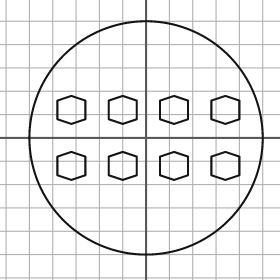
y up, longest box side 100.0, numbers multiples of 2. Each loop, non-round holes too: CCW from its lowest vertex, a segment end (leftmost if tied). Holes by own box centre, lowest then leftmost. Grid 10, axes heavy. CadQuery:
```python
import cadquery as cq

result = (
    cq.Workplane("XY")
    .moveTo(0.0, 0.0)
    .circle(50.0)
    .moveTo(-32.0, -18.0)
    .lineTo(-26.0, -16.0)
    .lineTo(-26.0, -8.0)
    .lineTo(-32.0, -6.0)
    .lineTo(-38.0, -8.0)
    .lineTo(-38.0, -16.0)
    .close()
    .moveTo(-10.0, -18.0)
    .lineTo(-4.0, -16.0)
    .lineTo(-4.0, -8.0)
    .lineTo(-10.0, -6.0)
    .lineTo(-16.0, -8.0)
    .lineTo(-16.0, -16.0)
    .close()
    .moveTo(12.0, -18.0)
    .lineTo(18.0, -16.0)
    .lineTo(18.0, -8.0)
    .lineTo(12.0, -6.0)
    .lineTo(6.0, -8.0)
    .lineTo(6.0, -16.0)
    .close()
    .moveTo(34.0, -18.0)
    .lineTo(40.0, -16.0)
    .lineTo(40.0, -8.0)
    .lineTo(34.0, -6.0)
    .lineTo(28.0, -8.0)
    .lineTo(28.0, -16.0)
    .close()
    .moveTo(-32.0, 6.0)
    .lineTo(-26.0, 8.0)
    .lineTo(-26.0, 16.0)
    .lineTo(-32.0, 18.0)
    .lineTo(-38.0, 16.0)
    .lineTo(-38.0, 8.0)
    .close()
    .moveTo(-10.0, 6.0)
    .lineTo(-4.0, 8.0)
    .lineTo(-4.0, 16.0)
    .lineTo(-10.0, 18.0)
    .lineTo(-16.0, 16.0)
    .lineTo(-16.0, 8.0)
    .close()
    .moveTo(12.0, 6.0)
    .lineTo(18.0, 8.0)
    .lineTo(18.0, 16.0)
    .lineTo(12.0, 18.0)
    .lineTo(6.0, 16.0)
    .lineTo(6.0, 8.0)
    .close()
    .moveTo(34.0, 6.0)
    .lineTo(40.0, 8.0)
    .lineTo(40.0, 16.0)
    .lineTo(34.0, 18.0)
    .lineTo(28.0, 16.0)
    .lineTo(28.0, 8.0)
    .close()
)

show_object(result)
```